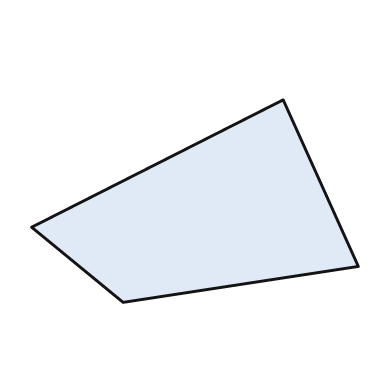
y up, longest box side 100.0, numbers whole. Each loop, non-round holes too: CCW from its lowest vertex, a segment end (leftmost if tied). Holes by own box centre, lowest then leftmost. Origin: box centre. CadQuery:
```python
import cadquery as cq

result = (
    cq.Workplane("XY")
    .moveTo(-22.0, -31.0)
    .lineTo(50.0, -20.0)
    .lineTo(27.0, 31.0)
    .lineTo(-50.0, -8.0)
    .close()
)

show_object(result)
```